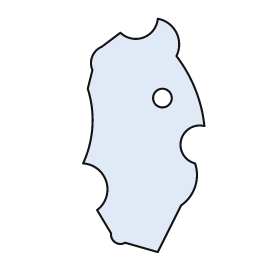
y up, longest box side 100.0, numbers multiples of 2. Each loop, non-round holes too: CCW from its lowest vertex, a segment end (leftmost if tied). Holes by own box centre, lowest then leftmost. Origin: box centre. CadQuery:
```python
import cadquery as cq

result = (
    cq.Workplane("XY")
    .moveTo(6.0, -50.0)
    .lineTo(16.0, -30.0)
    .threePointArc((22.0, -22.0), (22.0, -12.0))
    .threePointArc((16.0, -2.0), (26.0, 4.0))
    .threePointArc((22.0, 20.0), (14.0, 34.0))
    .threePointArc((14.0, 44.0), (6.0, 50.0))
    .threePointArc((0.0, 42.0), (-10.0, 44.0))
    .lineTo(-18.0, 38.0)
    .threePointArc((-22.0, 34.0), (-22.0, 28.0))
    .lineTo(-24.0, 20.0)
    .threePointArc((-22.0, 4.0), (-26.0, -12.0))
    .threePointArc((-16.0, -20.0), (-20.0, -32.0))
    .lineTo(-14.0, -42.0)
    .threePointArc((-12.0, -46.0), (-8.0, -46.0))
    .close()
    .moveTo(8.0, 16.0)
    .circle(4.0)
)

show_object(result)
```